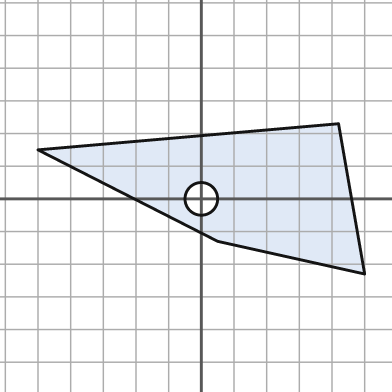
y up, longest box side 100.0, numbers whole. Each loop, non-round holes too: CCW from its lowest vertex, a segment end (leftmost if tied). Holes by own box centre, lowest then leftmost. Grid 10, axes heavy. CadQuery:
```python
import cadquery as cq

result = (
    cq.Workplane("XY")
    .moveTo(50.0, -23.0)
    .lineTo(42.0, 23.0)
    .lineTo(-50.0, 15.0)
    .lineTo(5.0, -13.0)
    .close()
    .moveTo(0.0, 0.0)
    .circle(5.0)
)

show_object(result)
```